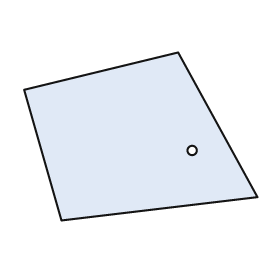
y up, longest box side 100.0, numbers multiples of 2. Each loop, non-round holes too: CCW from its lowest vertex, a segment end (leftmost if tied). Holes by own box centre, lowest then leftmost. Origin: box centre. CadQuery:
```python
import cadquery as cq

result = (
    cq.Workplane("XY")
    .moveTo(-34.0, -36.0)
    .lineTo(50.0, -26.0)
    .lineTo(16.0, 36.0)
    .lineTo(-50.0, 20.0)
    .close()
    .moveTo(22.0, -6.0)
    .circle(2.0)
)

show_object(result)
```